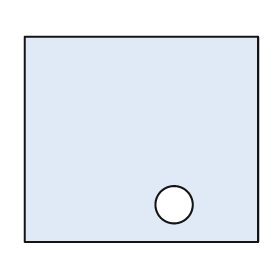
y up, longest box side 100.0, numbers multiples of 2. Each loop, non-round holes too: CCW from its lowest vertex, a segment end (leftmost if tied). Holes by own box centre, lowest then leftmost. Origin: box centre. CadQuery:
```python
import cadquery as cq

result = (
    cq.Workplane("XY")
    .moveTo(-50.0, -44.0)
    .lineTo(50.0, -44.0)
    .lineTo(50.0, 44.0)
    .lineTo(-50.0, 44.0)
    .close()
    .moveTo(14.0, -28.0)
    .circle(8.0)
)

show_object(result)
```